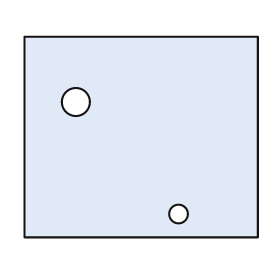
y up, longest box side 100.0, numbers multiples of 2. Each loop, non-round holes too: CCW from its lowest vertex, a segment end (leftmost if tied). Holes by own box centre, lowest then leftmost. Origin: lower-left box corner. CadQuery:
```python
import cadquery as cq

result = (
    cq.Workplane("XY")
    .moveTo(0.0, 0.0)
    .lineTo(100.0, 0.0)
    .lineTo(100.0, 86.0)
    .lineTo(0.0, 86.0)
    .close()
    .moveTo(66.0, 10.0)
    .circle(4.0)
    .moveTo(22.0, 58.0)
    .circle(6.0)
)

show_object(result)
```